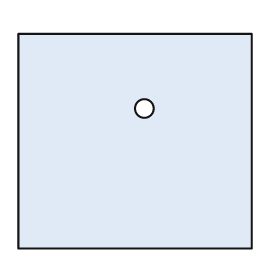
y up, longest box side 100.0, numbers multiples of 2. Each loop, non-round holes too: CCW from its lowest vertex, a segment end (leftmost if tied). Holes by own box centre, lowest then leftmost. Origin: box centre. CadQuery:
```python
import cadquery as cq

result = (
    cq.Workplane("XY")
    .moveTo(-50.0, -46.0)
    .lineTo(50.0, -46.0)
    .lineTo(50.0, 46.0)
    .lineTo(-50.0, 46.0)
    .close()
    .moveTo(4.0, 14.0)
    .circle(4.0)
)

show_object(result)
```